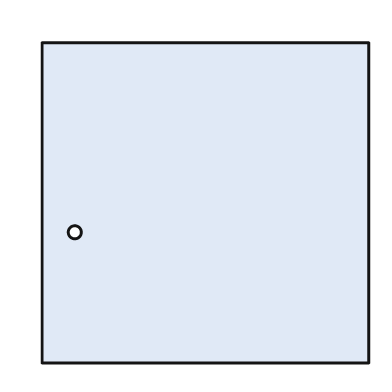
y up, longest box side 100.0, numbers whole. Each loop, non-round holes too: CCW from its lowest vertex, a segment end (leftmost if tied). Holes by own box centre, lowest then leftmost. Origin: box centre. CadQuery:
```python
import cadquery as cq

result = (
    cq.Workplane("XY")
    .moveTo(-50.0, -49.0)
    .lineTo(50.0, -49.0)
    .lineTo(50.0, 49.0)
    .lineTo(-50.0, 49.0)
    .close()
    .moveTo(-40.0, -9.0)
    .circle(2.0)
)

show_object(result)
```